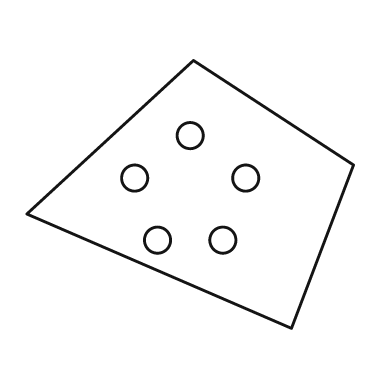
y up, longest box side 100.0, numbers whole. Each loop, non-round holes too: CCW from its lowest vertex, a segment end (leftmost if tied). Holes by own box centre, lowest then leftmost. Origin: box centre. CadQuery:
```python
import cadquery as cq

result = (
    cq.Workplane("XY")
    .moveTo(31.0, -41.0)
    .lineTo(50.0, 9.0)
    .lineTo(1.0, 41.0)
    .lineTo(-50.0, -6.0)
    .close()
    .moveTo(-10.0, -14.0)
    .circle(4.0)
    .moveTo(10.0, -14.0)
    .circle(4.0)
    .moveTo(-17.0, 5.0)
    .circle(4.0)
    .moveTo(17.0, 5.0)
    .circle(4.0)
    .moveTo(0.0, 18.0)
    .circle(4.0)
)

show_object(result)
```